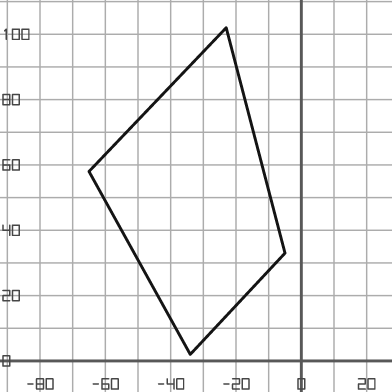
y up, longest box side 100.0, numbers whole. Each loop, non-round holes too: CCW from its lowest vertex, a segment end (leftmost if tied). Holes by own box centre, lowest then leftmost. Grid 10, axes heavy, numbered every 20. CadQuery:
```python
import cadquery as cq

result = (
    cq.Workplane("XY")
    .moveTo(-34.0, 2.0)
    .lineTo(-5.0, 33.0)
    .lineTo(-23.0, 102.0)
    .lineTo(-65.0, 58.0)
    .close()
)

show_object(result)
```